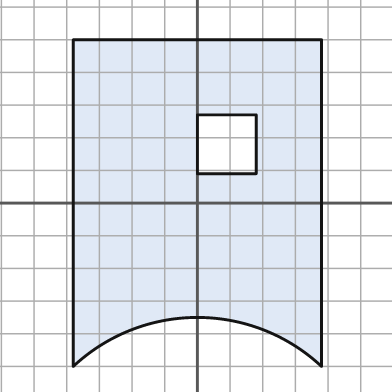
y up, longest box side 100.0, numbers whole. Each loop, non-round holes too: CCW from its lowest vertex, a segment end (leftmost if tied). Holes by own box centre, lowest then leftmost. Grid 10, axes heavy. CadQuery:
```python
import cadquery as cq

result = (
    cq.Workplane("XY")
    .moveTo(-38.0, -50.0)
    .threePointArc((0.0, -35.0), (38.0, -50.0))
    .lineTo(38.0, 50.0)
    .lineTo(-38.0, 50.0)
    .close()
    .moveTo(0.0, 9.0)
    .lineTo(18.0, 9.0)
    .lineTo(18.0, 27.0)
    .lineTo(0.0, 27.0)
    .close()
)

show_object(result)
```